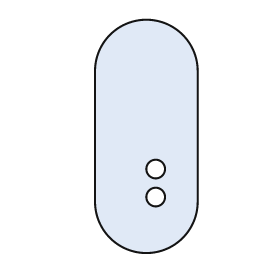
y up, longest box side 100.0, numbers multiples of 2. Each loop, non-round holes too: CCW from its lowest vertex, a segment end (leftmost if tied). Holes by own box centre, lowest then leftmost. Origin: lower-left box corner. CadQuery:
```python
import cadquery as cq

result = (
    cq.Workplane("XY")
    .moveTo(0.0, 22.0)
    .threePointArc((22.0, 0.0), (44.0, 22.0))
    .lineTo(44.0, 78.0)
    .threePointArc((22.0, 100.0), (0.0, 78.0))
    .close()
    .moveTo(26.0, 24.0)
    .circle(4.0)
    .moveTo(26.0, 36.0)
    .circle(4.0)
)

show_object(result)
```